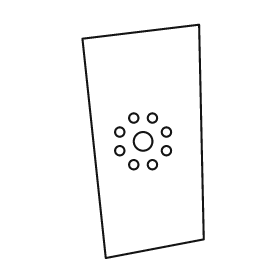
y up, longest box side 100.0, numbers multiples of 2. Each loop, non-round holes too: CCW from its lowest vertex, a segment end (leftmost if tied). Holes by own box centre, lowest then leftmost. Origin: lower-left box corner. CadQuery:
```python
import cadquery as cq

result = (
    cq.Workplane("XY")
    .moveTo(10.0, 0.0)
    .lineTo(52.0, 8.0)
    .lineTo(50.0, 100.0)
    .lineTo(0.0, 94.0)
    .close()
    .moveTo(22.0, 40.0)
    .circle(2.0)
    .moveTo(30.0, 40.0)
    .circle(2.0)
    .moveTo(16.0, 46.0)
    .circle(2.0)
    .moveTo(36.0, 46.0)
    .circle(2.0)
    .moveTo(26.0, 50.0)
    .circle(4.0)
    .moveTo(16.0, 54.0)
    .circle(2.0)
    .moveTo(36.0, 54.0)
    .circle(2.0)
    .moveTo(22.0, 60.0)
    .circle(2.0)
    .moveTo(30.0, 60.0)
    .circle(2.0)
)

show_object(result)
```